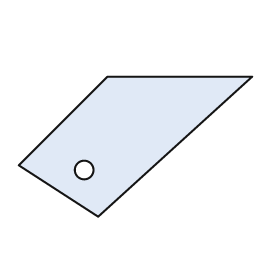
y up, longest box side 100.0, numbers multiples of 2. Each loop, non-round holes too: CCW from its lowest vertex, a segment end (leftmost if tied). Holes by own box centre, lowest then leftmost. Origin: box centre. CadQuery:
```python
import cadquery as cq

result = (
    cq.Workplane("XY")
    .moveTo(-16.0, -30.0)
    .lineTo(50.0, 30.0)
    .lineTo(-12.0, 30.0)
    .lineTo(-50.0, -8.0)
    .close()
    .moveTo(-22.0, -10.0)
    .circle(4.0)
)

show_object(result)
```